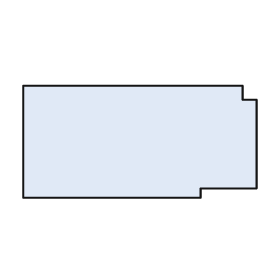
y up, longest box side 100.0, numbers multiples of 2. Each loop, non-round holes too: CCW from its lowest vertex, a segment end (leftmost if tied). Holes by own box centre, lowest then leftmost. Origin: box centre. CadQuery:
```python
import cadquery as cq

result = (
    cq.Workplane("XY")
    .moveTo(-50.0, -24.0)
    .lineTo(26.0, -24.0)
    .lineTo(26.0, -20.0)
    .lineTo(50.0, -20.0)
    .lineTo(50.0, 18.0)
    .lineTo(44.0, 18.0)
    .lineTo(44.0, 24.0)
    .lineTo(-50.0, 24.0)
    .close()
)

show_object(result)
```